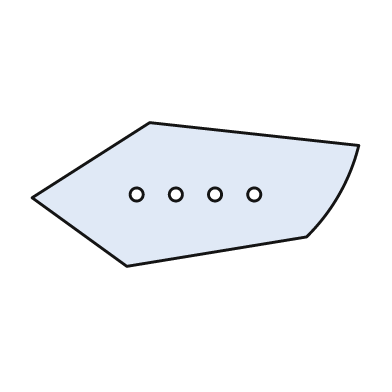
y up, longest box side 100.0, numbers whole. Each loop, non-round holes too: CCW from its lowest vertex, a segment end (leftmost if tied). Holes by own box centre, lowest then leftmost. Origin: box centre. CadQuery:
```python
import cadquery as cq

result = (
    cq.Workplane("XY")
    .moveTo(-21.0, -22.0)
    .lineTo(34.0, -13.0)
    .threePointArc((44.0, 0.0), (50.0, 15.0))
    .lineTo(-14.0, 22.0)
    .lineTo(-50.0, -1.0)
    .close()
    .moveTo(-18.0, 0.0)
    .circle(2.0)
    .moveTo(-6.0, 0.0)
    .circle(2.0)
    .moveTo(6.0, 0.0)
    .circle(2.0)
    .moveTo(18.0, 0.0)
    .circle(2.0)
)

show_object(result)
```